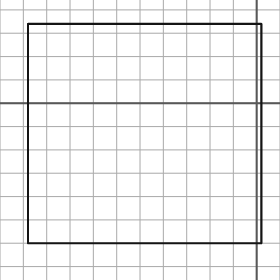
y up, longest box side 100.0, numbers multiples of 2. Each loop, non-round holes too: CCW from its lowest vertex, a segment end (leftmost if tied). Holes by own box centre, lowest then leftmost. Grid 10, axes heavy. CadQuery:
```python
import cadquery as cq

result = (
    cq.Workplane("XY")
    .moveTo(-98.0, -60.0)
    .lineTo(2.0, -60.0)
    .lineTo(2.0, 34.0)
    .lineTo(-98.0, 34.0)
    .close()
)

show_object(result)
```